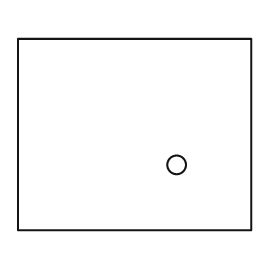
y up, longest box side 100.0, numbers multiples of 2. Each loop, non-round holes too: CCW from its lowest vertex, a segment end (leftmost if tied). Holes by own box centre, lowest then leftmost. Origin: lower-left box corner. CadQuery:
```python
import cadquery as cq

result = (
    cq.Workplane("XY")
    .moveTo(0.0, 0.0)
    .lineTo(100.0, 0.0)
    .lineTo(100.0, 82.0)
    .lineTo(0.0, 82.0)
    .close()
    .moveTo(68.0, 28.0)
    .circle(4.0)
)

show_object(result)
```